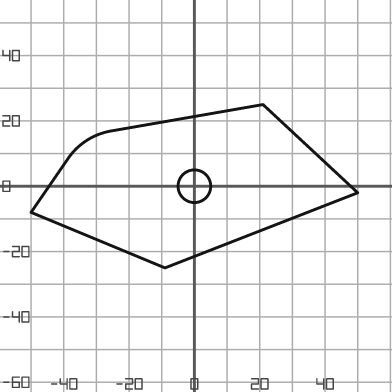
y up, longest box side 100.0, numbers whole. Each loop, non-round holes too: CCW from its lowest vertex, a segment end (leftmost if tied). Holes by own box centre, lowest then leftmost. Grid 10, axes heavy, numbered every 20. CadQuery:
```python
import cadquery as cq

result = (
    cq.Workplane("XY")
    .moveTo(-9.0, -25.0)
    .lineTo(50.0, -2.0)
    .lineTo(21.0, 25.0)
    .lineTo(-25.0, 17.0)
    .threePointArc((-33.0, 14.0), (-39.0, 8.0))
    .lineTo(-50.0, -8.0)
    .close()
    .moveTo(0.0, 0.0)
    .circle(5.0)
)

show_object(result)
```